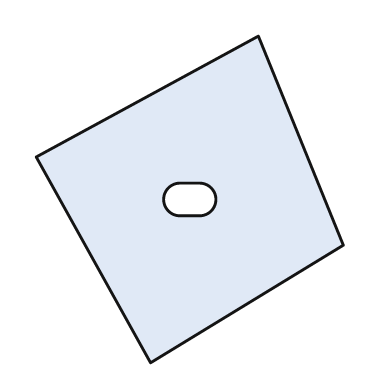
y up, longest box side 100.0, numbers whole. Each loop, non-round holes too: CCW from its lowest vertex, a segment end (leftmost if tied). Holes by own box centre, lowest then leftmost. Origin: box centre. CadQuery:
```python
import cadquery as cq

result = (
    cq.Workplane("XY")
    .moveTo(-12.0, -50.0)
    .lineTo(47.0, -14.0)
    .lineTo(21.0, 50.0)
    .lineTo(-47.0, 13.0)
    .close()
    .moveTo(-3.0, -5.0)
    .lineTo(3.0, -5.0)
    .threePointArc((8.0, 0.0), (3.0, 5.0))
    .lineTo(-3.0, 5.0)
    .threePointArc((-8.0, 0.0), (-3.0, -5.0))
    .close()
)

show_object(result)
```